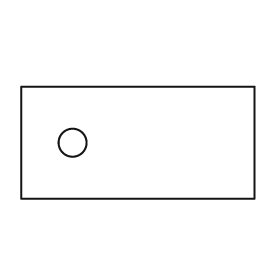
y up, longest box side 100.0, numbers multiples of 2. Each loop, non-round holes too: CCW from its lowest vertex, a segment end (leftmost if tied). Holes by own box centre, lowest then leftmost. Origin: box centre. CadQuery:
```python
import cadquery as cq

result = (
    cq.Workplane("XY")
    .moveTo(-50.0, -24.0)
    .lineTo(50.0, -24.0)
    .lineTo(50.0, 24.0)
    .lineTo(-50.0, 24.0)
    .close()
    .moveTo(-28.0, 0.0)
    .circle(6.0)
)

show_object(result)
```